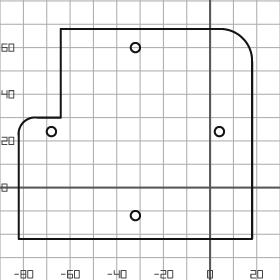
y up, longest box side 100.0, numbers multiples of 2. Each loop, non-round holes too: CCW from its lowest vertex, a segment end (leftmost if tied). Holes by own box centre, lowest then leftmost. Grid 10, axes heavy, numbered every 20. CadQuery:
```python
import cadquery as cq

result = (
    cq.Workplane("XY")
    .moveTo(-82.0, -22.0)
    .lineTo(18.0, -22.0)
    .lineTo(18.0, 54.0)
    .threePointArc((14.0, 64.0), (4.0, 68.0))
    .lineTo(-64.0, 68.0)
    .lineTo(-64.0, 30.0)
    .lineTo(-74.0, 30.0)
    .threePointArc((-80.0, 28.0), (-82.0, 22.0))
    .close()
    .moveTo(-32.0, -12.0)
    .circle(2.0)
    .moveTo(-68.0, 24.0)
    .circle(2.0)
    .moveTo(4.0, 24.0)
    .circle(2.0)
    .moveTo(-32.0, 60.0)
    .circle(2.0)
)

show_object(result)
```